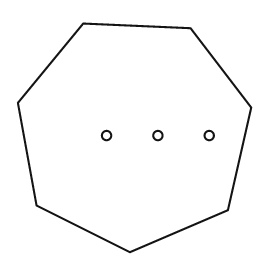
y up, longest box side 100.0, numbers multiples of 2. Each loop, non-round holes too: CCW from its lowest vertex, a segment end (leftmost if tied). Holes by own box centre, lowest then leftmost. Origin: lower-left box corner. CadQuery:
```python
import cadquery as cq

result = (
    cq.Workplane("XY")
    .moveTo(48.0, 0.0)
    .lineTo(90.0, 18.0)
    .lineTo(100.0, 62.0)
    .lineTo(74.0, 96.0)
    .lineTo(28.0, 98.0)
    .lineTo(0.0, 64.0)
    .lineTo(8.0, 20.0)
    .close()
    .moveTo(38.0, 50.0)
    .circle(2.0)
    .moveTo(60.0, 50.0)
    .circle(2.0)
    .moveTo(82.0, 50.0)
    .circle(2.0)
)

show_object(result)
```